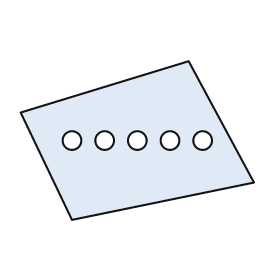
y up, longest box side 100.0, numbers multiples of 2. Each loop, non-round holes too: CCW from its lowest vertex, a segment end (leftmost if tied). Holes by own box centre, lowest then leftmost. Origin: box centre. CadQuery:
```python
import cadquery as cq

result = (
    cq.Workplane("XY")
    .moveTo(-28.0, -34.0)
    .lineTo(50.0, -18.0)
    .lineTo(22.0, 34.0)
    .lineTo(-50.0, 12.0)
    .close()
    .moveTo(-28.0, 0.0)
    .circle(4.0)
    .moveTo(-14.0, 0.0)
    .circle(4.0)
    .moveTo(0.0, 0.0)
    .circle(4.0)
    .moveTo(14.0, 0.0)
    .circle(4.0)
    .moveTo(28.0, 0.0)
    .circle(4.0)
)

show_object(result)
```